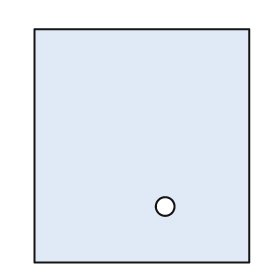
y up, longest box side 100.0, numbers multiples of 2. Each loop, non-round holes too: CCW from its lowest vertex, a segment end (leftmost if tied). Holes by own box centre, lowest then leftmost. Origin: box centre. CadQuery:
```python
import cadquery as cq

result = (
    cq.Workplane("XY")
    .moveTo(-46.0, -50.0)
    .lineTo(46.0, -50.0)
    .lineTo(46.0, 50.0)
    .lineTo(-46.0, 50.0)
    .close()
    .moveTo(10.0, -26.0)
    .circle(4.0)
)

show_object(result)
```